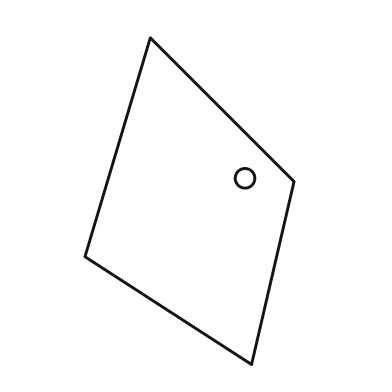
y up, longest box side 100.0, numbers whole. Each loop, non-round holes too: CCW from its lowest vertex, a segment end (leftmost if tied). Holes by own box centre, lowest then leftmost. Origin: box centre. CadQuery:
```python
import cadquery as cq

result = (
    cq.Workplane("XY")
    .moveTo(19.0, -50.0)
    .lineTo(32.0, 6.0)
    .lineTo(-12.0, 50.0)
    .lineTo(-32.0, -17.0)
    .close()
    .moveTo(17.0, 7.0)
    .circle(3.0)
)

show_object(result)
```